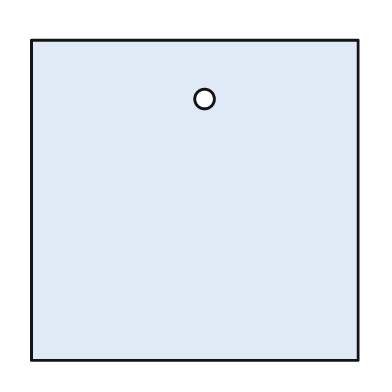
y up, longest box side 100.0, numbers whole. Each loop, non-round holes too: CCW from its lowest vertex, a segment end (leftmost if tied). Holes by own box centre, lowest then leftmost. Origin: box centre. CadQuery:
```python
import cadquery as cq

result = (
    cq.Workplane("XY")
    .moveTo(-50.0, -49.0)
    .lineTo(50.0, -49.0)
    .lineTo(50.0, 49.0)
    .lineTo(-50.0, 49.0)
    .close()
    .moveTo(3.0, 31.0)
    .circle(3.0)
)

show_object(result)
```